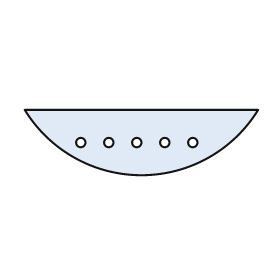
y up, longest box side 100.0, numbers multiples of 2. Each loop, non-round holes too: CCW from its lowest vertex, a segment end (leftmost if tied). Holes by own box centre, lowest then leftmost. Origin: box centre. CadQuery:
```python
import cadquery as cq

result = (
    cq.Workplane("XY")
    .moveTo(-50.0, 14.0)
    .threePointArc((0.0, -14.0), (50.0, 14.0))
    .close()
    .moveTo(-26.0, 0.0)
    .circle(2.0)
    .moveTo(-14.0, 0.0)
    .circle(2.0)
    .moveTo(-2.0, 0.0)
    .circle(2.0)
    .moveTo(10.0, 0.0)
    .circle(2.0)
    .moveTo(22.0, 0.0)
    .circle(2.0)
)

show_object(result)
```